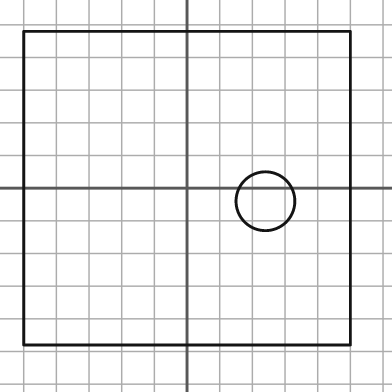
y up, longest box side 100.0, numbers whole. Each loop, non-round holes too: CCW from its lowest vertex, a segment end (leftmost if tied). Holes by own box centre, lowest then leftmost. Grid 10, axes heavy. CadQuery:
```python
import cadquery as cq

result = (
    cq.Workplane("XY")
    .moveTo(-50.0, -48.0)
    .lineTo(50.0, -48.0)
    .lineTo(50.0, 48.0)
    .lineTo(-50.0, 48.0)
    .close()
    .moveTo(24.0, -4.0)
    .circle(9.0)
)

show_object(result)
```